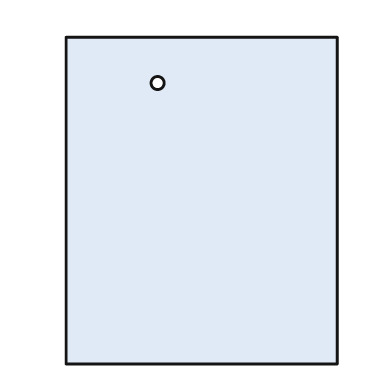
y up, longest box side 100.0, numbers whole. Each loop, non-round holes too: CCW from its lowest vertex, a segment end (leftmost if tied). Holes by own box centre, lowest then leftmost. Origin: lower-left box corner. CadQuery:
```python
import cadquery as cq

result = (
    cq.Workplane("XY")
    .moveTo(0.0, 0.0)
    .lineTo(83.0, 0.0)
    .lineTo(83.0, 100.0)
    .lineTo(0.0, 100.0)
    .close()
    .moveTo(28.0, 86.0)
    .circle(2.0)
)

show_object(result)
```